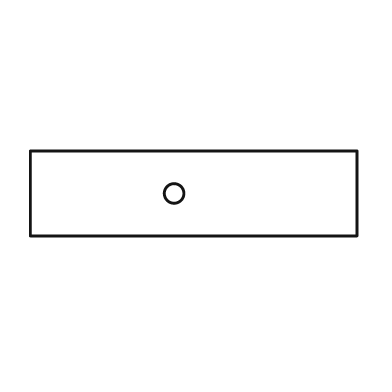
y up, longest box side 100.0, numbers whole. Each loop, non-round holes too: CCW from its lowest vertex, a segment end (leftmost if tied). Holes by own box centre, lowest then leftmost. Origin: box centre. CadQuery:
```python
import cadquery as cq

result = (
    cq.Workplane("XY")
    .moveTo(-50.0, -13.0)
    .lineTo(50.0, -13.0)
    .lineTo(50.0, 13.0)
    .lineTo(-50.0, 13.0)
    .close()
    .moveTo(-6.0, 0.0)
    .circle(3.0)
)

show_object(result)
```